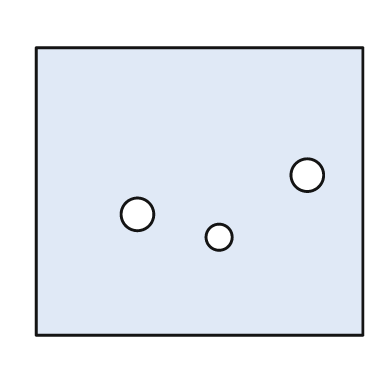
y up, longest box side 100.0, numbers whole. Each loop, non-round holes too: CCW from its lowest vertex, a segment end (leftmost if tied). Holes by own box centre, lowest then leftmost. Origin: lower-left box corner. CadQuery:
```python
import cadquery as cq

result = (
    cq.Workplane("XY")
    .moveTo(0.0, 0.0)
    .lineTo(100.0, 0.0)
    .lineTo(100.0, 88.0)
    .lineTo(0.0, 88.0)
    .close()
    .moveTo(56.0, 30.0)
    .circle(4.0)
    .moveTo(31.0, 37.0)
    .circle(5.0)
    .moveTo(83.0, 49.0)
    .circle(5.0)
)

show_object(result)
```